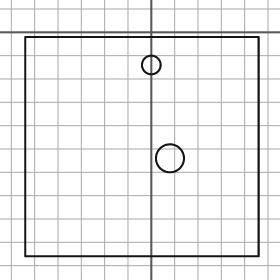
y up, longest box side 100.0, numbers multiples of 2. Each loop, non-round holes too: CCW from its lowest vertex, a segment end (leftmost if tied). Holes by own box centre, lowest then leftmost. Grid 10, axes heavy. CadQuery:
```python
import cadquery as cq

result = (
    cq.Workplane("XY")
    .moveTo(-54.0, -96.0)
    .lineTo(46.0, -96.0)
    .lineTo(46.0, -2.0)
    .lineTo(-54.0, -2.0)
    .close()
    .moveTo(8.0, -54.0)
    .circle(6.0)
    .moveTo(0.0, -14.0)
    .circle(4.0)
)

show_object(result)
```